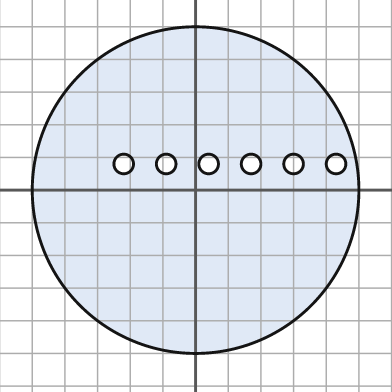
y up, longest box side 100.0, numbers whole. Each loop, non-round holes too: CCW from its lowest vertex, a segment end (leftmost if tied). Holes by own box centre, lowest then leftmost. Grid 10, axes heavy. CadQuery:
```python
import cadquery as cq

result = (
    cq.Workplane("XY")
    .moveTo(0.0, 0.0)
    .circle(50.0)
    .moveTo(-22.0, 8.0)
    .circle(3.0)
    .moveTo(-9.0, 8.0)
    .circle(3.0)
    .moveTo(4.0, 8.0)
    .circle(3.0)
    .moveTo(17.0, 8.0)
    .circle(3.0)
    .moveTo(30.0, 8.0)
    .circle(3.0)
    .moveTo(43.0, 8.0)
    .circle(3.0)
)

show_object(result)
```